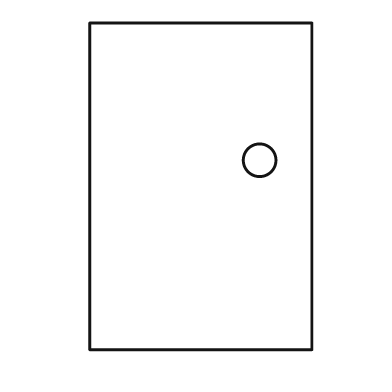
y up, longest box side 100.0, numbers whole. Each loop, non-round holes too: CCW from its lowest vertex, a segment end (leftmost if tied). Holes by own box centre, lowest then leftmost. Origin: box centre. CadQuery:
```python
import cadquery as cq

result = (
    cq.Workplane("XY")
    .moveTo(-34.0, -50.0)
    .lineTo(34.0, -50.0)
    .lineTo(34.0, 50.0)
    .lineTo(-34.0, 50.0)
    .close()
    .moveTo(18.0, 8.0)
    .circle(5.0)
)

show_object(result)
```